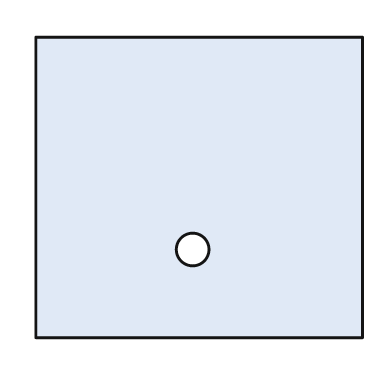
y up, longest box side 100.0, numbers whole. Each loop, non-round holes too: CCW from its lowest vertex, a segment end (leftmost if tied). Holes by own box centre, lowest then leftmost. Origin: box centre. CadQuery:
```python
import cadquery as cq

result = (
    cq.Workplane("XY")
    .moveTo(-50.0, -46.0)
    .lineTo(50.0, -46.0)
    .lineTo(50.0, 46.0)
    .lineTo(-50.0, 46.0)
    .close()
    .moveTo(-2.0, -19.0)
    .circle(5.0)
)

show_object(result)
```